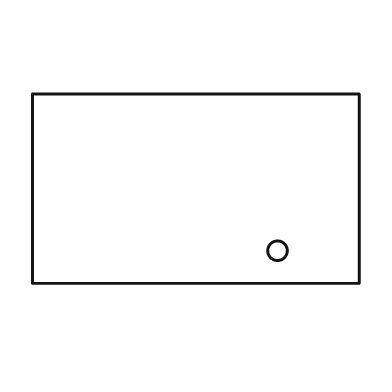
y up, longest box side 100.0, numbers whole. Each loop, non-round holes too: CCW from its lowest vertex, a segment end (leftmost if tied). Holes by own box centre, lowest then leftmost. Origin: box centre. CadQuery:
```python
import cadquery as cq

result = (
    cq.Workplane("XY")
    .moveTo(-50.0, -29.0)
    .lineTo(50.0, -29.0)
    .lineTo(50.0, 29.0)
    .lineTo(-50.0, 29.0)
    .close()
    .moveTo(25.0, -19.0)
    .circle(3.0)
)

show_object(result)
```